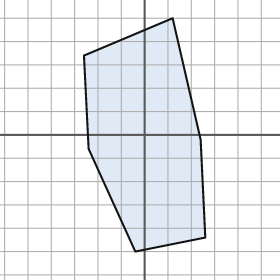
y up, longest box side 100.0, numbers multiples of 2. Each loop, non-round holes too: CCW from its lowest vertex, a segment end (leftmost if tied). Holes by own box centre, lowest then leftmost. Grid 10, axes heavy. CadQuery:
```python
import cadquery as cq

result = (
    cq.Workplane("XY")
    .moveTo(-4.0, -50.0)
    .lineTo(26.0, -44.0)
    .lineTo(24.0, -2.0)
    .lineTo(12.0, 50.0)
    .lineTo(-26.0, 34.0)
    .lineTo(-24.0, -6.0)
    .close()
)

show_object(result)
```